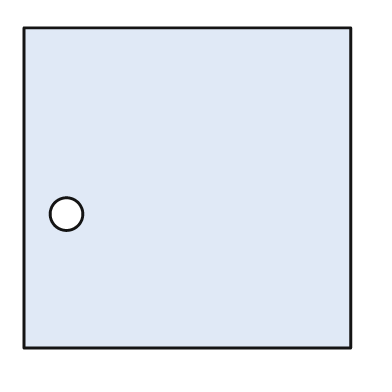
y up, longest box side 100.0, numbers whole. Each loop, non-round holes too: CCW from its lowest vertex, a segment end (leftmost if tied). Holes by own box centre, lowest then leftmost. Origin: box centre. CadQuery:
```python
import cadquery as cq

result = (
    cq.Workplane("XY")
    .moveTo(-50.0, -49.0)
    .lineTo(50.0, -49.0)
    .lineTo(50.0, 49.0)
    .lineTo(-50.0, 49.0)
    .close()
    .moveTo(-37.0, -8.0)
    .circle(5.0)
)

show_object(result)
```